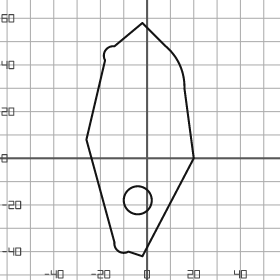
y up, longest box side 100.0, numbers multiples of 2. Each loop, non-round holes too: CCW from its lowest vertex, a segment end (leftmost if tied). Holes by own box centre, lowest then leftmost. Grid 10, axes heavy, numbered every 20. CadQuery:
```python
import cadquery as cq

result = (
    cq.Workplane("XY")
    .moveTo(-2.0, -42.0)
    .lineTo(20.0, 0.0)
    .lineTo(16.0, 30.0)
    .threePointArc((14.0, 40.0), (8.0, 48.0))
    .lineTo(-2.0, 58.0)
    .lineTo(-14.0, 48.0)
    .threePointArc((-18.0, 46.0), (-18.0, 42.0))
    .lineTo(-26.0, 8.0)
    .lineTo(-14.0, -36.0)
    .threePointArc((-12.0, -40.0), (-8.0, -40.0))
    .close()
    .moveTo(-4.0, -18.0)
    .circle(6.0)
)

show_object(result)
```